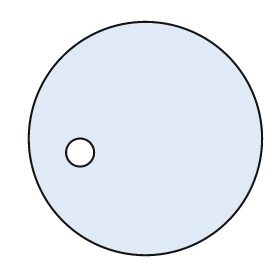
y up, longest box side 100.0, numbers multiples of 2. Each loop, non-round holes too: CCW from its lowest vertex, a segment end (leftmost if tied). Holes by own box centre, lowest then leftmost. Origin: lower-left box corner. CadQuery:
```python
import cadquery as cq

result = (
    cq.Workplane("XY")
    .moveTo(50.0, 50.0)
    .circle(50.0)
    .moveTo(22.0, 44.0)
    .circle(6.0)
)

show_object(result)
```